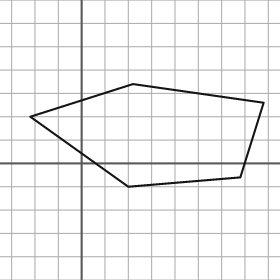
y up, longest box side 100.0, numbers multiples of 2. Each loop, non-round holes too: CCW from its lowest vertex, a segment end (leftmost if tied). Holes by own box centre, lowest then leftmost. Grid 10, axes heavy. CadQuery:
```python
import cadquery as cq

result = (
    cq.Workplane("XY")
    .moveTo(20.0, -10.0)
    .lineTo(68.0, -6.0)
    .lineTo(78.0, 26.0)
    .lineTo(22.0, 34.0)
    .lineTo(-22.0, 20.0)
    .close()
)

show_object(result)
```